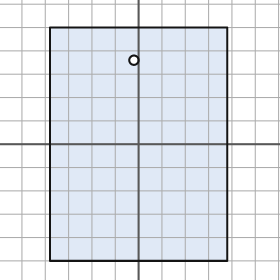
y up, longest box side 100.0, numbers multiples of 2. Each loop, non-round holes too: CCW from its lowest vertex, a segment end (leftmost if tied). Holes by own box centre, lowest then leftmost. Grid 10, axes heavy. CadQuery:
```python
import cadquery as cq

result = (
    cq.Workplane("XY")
    .moveTo(-38.0, -50.0)
    .lineTo(38.0, -50.0)
    .lineTo(38.0, 50.0)
    .lineTo(-38.0, 50.0)
    .close()
    .moveTo(-2.0, 36.0)
    .circle(2.0)
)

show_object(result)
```